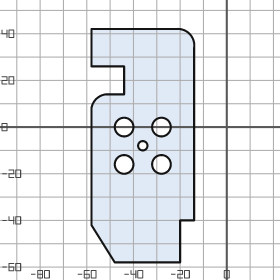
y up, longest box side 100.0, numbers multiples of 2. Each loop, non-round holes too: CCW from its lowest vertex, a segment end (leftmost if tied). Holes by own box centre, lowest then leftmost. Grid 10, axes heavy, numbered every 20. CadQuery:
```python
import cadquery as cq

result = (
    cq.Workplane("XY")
    .moveTo(-48.0, -58.0)
    .lineTo(-20.0, -58.0)
    .lineTo(-20.0, -40.0)
    .lineTo(-14.0, -40.0)
    .lineTo(-14.0, 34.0)
    .threePointArc((-16.0, 40.0), (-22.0, 42.0))
    .lineTo(-58.0, 42.0)
    .lineTo(-58.0, 26.0)
    .lineTo(-44.0, 26.0)
    .lineTo(-44.0, 14.0)
    .lineTo(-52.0, 14.0)
    .threePointArc((-56.0, 12.0), (-58.0, 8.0))
    .lineTo(-58.0, -42.0)
    .close()
    .moveTo(-44.0, -16.0)
    .circle(4.0)
    .moveTo(-28.0, -16.0)
    .circle(4.0)
    .moveTo(-36.0, -8.0)
    .circle(2.0)
    .moveTo(-44.0, 0.0)
    .circle(4.0)
    .moveTo(-28.0, 0.0)
    .circle(4.0)
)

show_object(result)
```